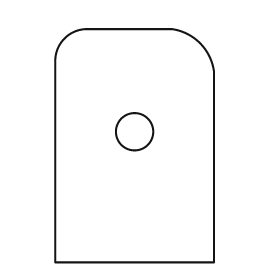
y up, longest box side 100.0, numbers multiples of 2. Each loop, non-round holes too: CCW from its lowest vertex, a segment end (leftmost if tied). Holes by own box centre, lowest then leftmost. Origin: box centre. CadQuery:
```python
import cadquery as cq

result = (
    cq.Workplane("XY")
    .moveTo(-34.0, -50.0)
    .lineTo(34.0, -50.0)
    .lineTo(34.0, 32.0)
    .threePointArc((28.0, 44.0), (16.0, 50.0))
    .lineTo(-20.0, 50.0)
    .threePointArc((-30.0, 46.0), (-34.0, 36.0))
    .close()
    .moveTo(0.0, 6.0)
    .circle(8.0)
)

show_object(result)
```